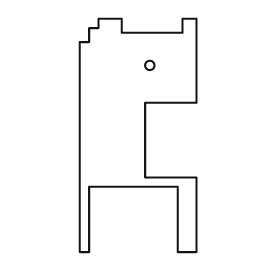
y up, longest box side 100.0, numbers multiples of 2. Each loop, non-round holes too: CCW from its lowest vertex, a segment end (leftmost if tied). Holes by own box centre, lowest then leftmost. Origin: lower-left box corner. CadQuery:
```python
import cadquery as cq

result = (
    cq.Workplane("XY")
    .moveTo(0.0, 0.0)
    .lineTo(4.0, 0.0)
    .lineTo(4.0, 28.0)
    .lineTo(42.0, 28.0)
    .lineTo(42.0, 0.0)
    .lineTo(50.0, 0.0)
    .lineTo(50.0, 32.0)
    .lineTo(28.0, 32.0)
    .lineTo(28.0, 64.0)
    .lineTo(50.0, 64.0)
    .lineTo(50.0, 100.0)
    .lineTo(44.0, 100.0)
    .lineTo(44.0, 94.0)
    .lineTo(18.0, 94.0)
    .lineTo(18.0, 100.0)
    .lineTo(8.0, 100.0)
    .lineTo(8.0, 96.0)
    .lineTo(4.0, 96.0)
    .lineTo(4.0, 90.0)
    .lineTo(0.0, 90.0)
    .close()
    .moveTo(30.0, 80.0)
    .circle(2.0)
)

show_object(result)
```